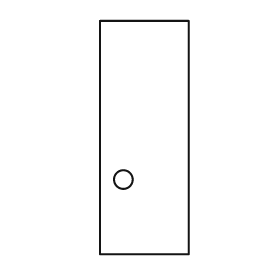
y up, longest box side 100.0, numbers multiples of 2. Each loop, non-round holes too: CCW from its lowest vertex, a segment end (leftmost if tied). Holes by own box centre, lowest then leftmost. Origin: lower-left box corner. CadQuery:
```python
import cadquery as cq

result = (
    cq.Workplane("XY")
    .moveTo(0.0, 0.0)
    .lineTo(38.0, 0.0)
    .lineTo(38.0, 100.0)
    .lineTo(0.0, 100.0)
    .close()
    .moveTo(10.0, 32.0)
    .circle(4.0)
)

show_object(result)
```